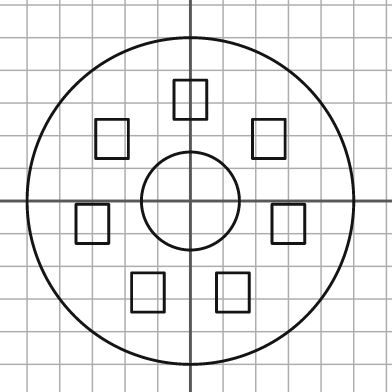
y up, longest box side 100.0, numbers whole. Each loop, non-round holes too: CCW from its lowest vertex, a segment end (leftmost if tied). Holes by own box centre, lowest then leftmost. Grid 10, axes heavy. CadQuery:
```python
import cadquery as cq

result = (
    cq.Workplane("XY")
    .moveTo(0.0, 0.0)
    .circle(50.0)
    .moveTo(-18.0, -34.0)
    .lineTo(-8.0, -34.0)
    .lineTo(-8.0, -22.0)
    .lineTo(-18.0, -22.0)
    .close()
    .moveTo(8.0, -34.0)
    .lineTo(18.0, -34.0)
    .lineTo(18.0, -22.0)
    .lineTo(8.0, -22.0)
    .close()
    .moveTo(-35.0, -13.0)
    .lineTo(-25.0, -13.0)
    .lineTo(-25.0, -1.0)
    .lineTo(-35.0, -1.0)
    .close()
    .moveTo(25.0, -13.0)
    .lineTo(35.0, -13.0)
    .lineTo(35.0, -1.0)
    .lineTo(25.0, -1.0)
    .close()
    .moveTo(0.0, 0.0)
    .circle(15.0)
    .moveTo(-29.0, 13.0)
    .lineTo(-19.0, 13.0)
    .lineTo(-19.0, 25.0)
    .lineTo(-29.0, 25.0)
    .close()
    .moveTo(19.0, 13.0)
    .lineTo(29.0, 13.0)
    .lineTo(29.0, 25.0)
    .lineTo(19.0, 25.0)
    .close()
    .moveTo(-5.0, 25.0)
    .lineTo(5.0, 25.0)
    .lineTo(5.0, 37.0)
    .lineTo(-5.0, 37.0)
    .close()
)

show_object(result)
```